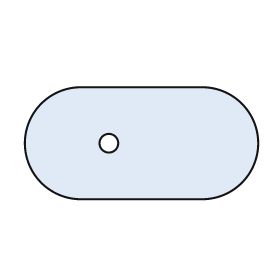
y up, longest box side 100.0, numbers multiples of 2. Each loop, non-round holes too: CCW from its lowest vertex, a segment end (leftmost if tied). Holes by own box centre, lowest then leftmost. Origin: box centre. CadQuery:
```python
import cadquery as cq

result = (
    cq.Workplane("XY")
    .moveTo(-26.0, -24.0)
    .lineTo(26.0, -24.0)
    .threePointArc((50.0, 0.0), (26.0, 24.0))
    .lineTo(-26.0, 24.0)
    .threePointArc((-50.0, 0.0), (-26.0, -24.0))
    .close()
    .moveTo(-14.0, 0.0)
    .circle(4.0)
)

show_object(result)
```